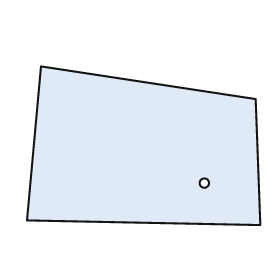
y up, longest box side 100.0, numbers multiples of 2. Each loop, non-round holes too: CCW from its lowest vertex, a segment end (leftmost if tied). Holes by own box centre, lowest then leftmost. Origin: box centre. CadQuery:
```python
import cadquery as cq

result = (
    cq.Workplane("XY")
    .moveTo(50.0, -34.0)
    .lineTo(48.0, 20.0)
    .lineTo(-44.0, 34.0)
    .lineTo(-50.0, -32.0)
    .close()
    .moveTo(26.0, -16.0)
    .circle(2.0)
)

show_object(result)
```